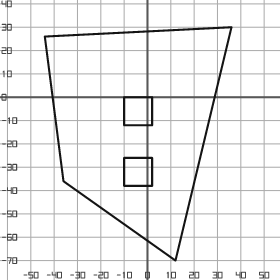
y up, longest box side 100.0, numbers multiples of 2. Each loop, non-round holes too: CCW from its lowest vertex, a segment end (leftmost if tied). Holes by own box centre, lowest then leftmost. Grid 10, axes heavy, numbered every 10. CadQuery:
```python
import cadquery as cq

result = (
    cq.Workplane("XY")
    .moveTo(12.0, -70.0)
    .lineTo(36.0, 30.0)
    .lineTo(-44.0, 26.0)
    .lineTo(-36.0, -36.0)
    .close()
    .moveTo(-10.0, -38.0)
    .lineTo(2.0, -38.0)
    .lineTo(2.0, -26.0)
    .lineTo(-10.0, -26.0)
    .close()
    .moveTo(-10.0, -12.0)
    .lineTo(2.0, -12.0)
    .lineTo(2.0, 0.0)
    .lineTo(-10.0, 0.0)
    .close()
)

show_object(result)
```